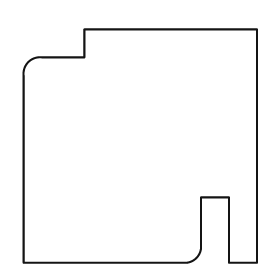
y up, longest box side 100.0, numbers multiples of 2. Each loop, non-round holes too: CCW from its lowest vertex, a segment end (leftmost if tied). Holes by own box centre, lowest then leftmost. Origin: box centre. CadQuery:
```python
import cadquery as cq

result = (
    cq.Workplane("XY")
    .moveTo(-50.0, -50.0)
    .lineTo(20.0, -50.0)
    .threePointArc((24.0, -48.0), (26.0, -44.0))
    .lineTo(26.0, -22.0)
    .lineTo(38.0, -22.0)
    .lineTo(38.0, -50.0)
    .lineTo(50.0, -50.0)
    .lineTo(50.0, 50.0)
    .lineTo(-24.0, 50.0)
    .lineTo(-24.0, 38.0)
    .lineTo(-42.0, 38.0)
    .threePointArc((-48.0, 36.0), (-50.0, 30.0))
    .close()
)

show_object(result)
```